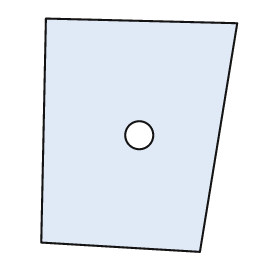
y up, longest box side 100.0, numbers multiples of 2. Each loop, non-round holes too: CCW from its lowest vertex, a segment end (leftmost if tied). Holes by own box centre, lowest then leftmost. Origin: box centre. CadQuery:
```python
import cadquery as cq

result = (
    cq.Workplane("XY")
    .moveTo(26.0, -50.0)
    .lineTo(42.0, 48.0)
    .lineTo(-40.0, 50.0)
    .lineTo(-42.0, -46.0)
    .close()
    .moveTo(0.0, 0.0)
    .circle(6.0)
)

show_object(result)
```